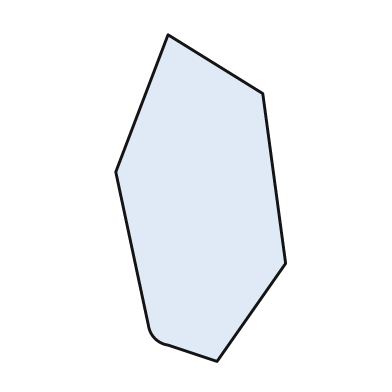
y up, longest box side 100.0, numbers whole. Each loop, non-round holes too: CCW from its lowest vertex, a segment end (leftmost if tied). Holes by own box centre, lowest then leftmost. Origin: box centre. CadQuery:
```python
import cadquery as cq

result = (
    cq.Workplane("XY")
    .moveTo(5.0, -50.0)
    .lineTo(26.0, -20.0)
    .lineTo(19.0, 32.0)
    .lineTo(-10.0, 50.0)
    .lineTo(-26.0, 8.0)
    .lineTo(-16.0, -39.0)
    .threePointArc((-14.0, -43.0), (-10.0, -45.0))
    .close()
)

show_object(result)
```